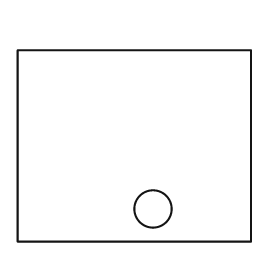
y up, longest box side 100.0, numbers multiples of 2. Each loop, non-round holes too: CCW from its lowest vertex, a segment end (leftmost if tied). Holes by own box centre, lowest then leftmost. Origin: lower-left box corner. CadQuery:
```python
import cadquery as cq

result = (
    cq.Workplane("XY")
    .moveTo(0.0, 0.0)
    .lineTo(100.0, 0.0)
    .lineTo(100.0, 82.0)
    .lineTo(0.0, 82.0)
    .close()
    .moveTo(58.0, 14.0)
    .circle(8.0)
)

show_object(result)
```